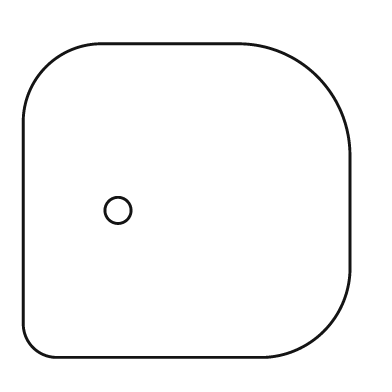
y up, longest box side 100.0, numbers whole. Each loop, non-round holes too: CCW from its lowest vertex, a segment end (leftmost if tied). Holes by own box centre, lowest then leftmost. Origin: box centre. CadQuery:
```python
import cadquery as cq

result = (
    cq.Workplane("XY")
    .moveTo(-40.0, -48.0)
    .lineTo(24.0, -48.0)
    .threePointArc((42.0, -40.0), (50.0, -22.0))
    .lineTo(50.0, 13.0)
    .threePointArc((40.0, 38.0), (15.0, 48.0))
    .lineTo(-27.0, 48.0)
    .threePointArc((-43.0, 41.0), (-50.0, 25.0))
    .lineTo(-50.0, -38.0)
    .threePointArc((-47.0, -45.0), (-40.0, -48.0))
    .close()
    .moveTo(-21.0, -3.0)
    .circle(4.0)
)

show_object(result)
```